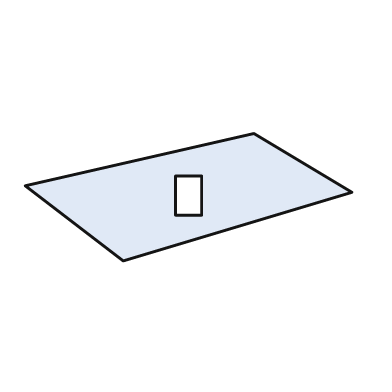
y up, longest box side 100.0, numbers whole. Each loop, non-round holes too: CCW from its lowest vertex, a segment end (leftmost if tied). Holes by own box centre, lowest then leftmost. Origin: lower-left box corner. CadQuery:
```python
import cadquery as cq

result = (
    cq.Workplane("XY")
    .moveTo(30.0, 0.0)
    .lineTo(100.0, 21.0)
    .lineTo(70.0, 39.0)
    .lineTo(0.0, 23.0)
    .close()
    .moveTo(46.0, 14.0)
    .lineTo(54.0, 14.0)
    .lineTo(54.0, 26.0)
    .lineTo(46.0, 26.0)
    .close()
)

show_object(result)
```